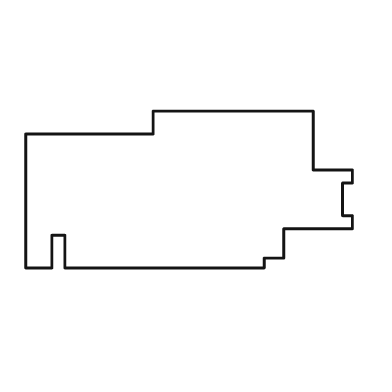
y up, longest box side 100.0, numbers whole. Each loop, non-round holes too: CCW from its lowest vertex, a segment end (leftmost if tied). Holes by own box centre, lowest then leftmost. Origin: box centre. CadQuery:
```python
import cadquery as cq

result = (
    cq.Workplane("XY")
    .moveTo(-50.0, -24.0)
    .lineTo(-42.0, -24.0)
    .lineTo(-42.0, -14.0)
    .lineTo(-38.0, -14.0)
    .lineTo(-38.0, -24.0)
    .lineTo(23.0, -24.0)
    .lineTo(23.0, -21.0)
    .lineTo(29.0, -21.0)
    .lineTo(29.0, -12.0)
    .lineTo(50.0, -12.0)
    .lineTo(50.0, -8.0)
    .lineTo(47.0, -8.0)
    .lineTo(47.0, 2.0)
    .lineTo(50.0, 2.0)
    .lineTo(50.0, 6.0)
    .lineTo(38.0, 6.0)
    .lineTo(38.0, 24.0)
    .lineTo(-11.0, 24.0)
    .lineTo(-11.0, 17.0)
    .lineTo(-50.0, 17.0)
    .close()
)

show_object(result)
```